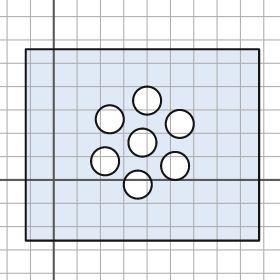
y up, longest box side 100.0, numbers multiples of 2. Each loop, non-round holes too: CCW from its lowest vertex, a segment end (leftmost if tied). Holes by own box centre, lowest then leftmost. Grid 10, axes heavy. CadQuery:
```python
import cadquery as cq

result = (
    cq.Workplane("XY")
    .moveTo(-12.0, -26.0)
    .lineTo(88.0, -26.0)
    .lineTo(88.0, 56.0)
    .lineTo(-12.0, 56.0)
    .close()
    .moveTo(36.0, -2.0)
    .circle(6.0)
    .moveTo(52.0, 6.0)
    .circle(6.0)
    .moveTo(22.0, 8.0)
    .circle(6.0)
    .moveTo(38.0, 16.0)
    .circle(6.0)
    .moveTo(54.0, 24.0)
    .circle(6.0)
    .moveTo(24.0, 26.0)
    .circle(6.0)
    .moveTo(40.0, 34.0)
    .circle(6.0)
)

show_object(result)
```